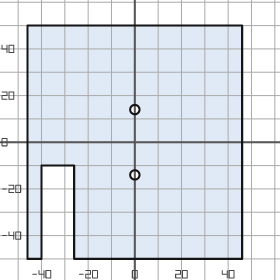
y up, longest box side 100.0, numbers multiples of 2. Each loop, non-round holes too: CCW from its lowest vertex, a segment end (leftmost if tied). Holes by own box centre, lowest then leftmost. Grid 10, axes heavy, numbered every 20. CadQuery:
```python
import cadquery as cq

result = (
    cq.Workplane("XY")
    .moveTo(-46.0, -50.0)
    .lineTo(-40.0, -50.0)
    .lineTo(-40.0, -10.0)
    .lineTo(-26.0, -10.0)
    .lineTo(-26.0, -50.0)
    .lineTo(46.0, -50.0)
    .lineTo(46.0, 50.0)
    .lineTo(-46.0, 50.0)
    .close()
    .moveTo(0.0, -14.0)
    .circle(2.0)
    .moveTo(0.0, 14.0)
    .circle(2.0)
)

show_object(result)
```